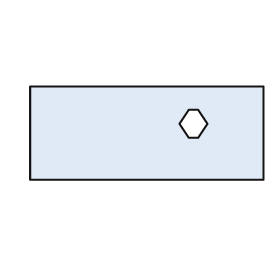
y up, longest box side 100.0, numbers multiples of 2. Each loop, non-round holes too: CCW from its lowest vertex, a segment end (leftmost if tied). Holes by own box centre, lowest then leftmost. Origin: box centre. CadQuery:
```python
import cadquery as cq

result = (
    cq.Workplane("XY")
    .moveTo(-50.0, -20.0)
    .lineTo(50.0, -20.0)
    .lineTo(50.0, 20.0)
    .lineTo(-50.0, 20.0)
    .close()
    .moveTo(18.0, -2.0)
    .lineTo(22.0, -2.0)
    .lineTo(26.0, 4.0)
    .lineTo(22.0, 10.0)
    .lineTo(18.0, 10.0)
    .lineTo(14.0, 4.0)
    .close()
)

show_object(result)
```